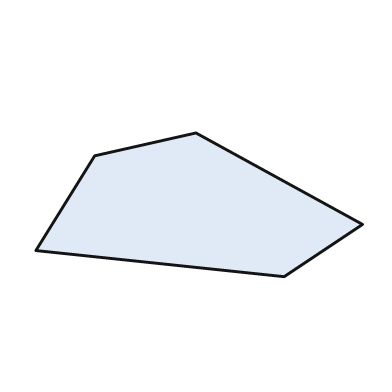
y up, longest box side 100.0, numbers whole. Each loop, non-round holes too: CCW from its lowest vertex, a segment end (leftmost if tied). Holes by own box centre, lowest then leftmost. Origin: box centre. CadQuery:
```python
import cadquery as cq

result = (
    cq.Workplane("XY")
    .moveTo(26.0, -22.0)
    .lineTo(50.0, -6.0)
    .lineTo(-1.0, 22.0)
    .lineTo(-32.0, 15.0)
    .lineTo(-50.0, -14.0)
    .close()
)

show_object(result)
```